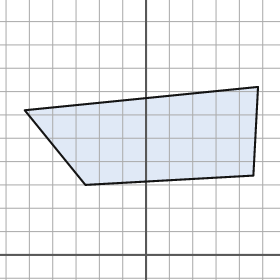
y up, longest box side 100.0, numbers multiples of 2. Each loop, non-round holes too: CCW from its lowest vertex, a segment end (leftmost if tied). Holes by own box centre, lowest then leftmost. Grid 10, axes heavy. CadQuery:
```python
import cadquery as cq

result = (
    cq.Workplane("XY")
    .moveTo(-26.0, 30.0)
    .lineTo(46.0, 34.0)
    .lineTo(48.0, 72.0)
    .lineTo(-52.0, 62.0)
    .close()
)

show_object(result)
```